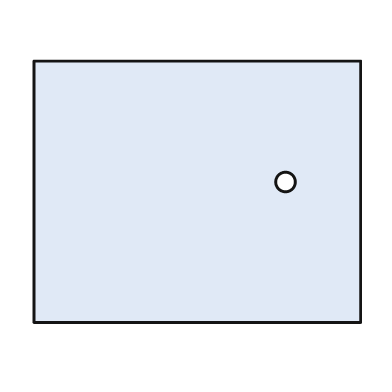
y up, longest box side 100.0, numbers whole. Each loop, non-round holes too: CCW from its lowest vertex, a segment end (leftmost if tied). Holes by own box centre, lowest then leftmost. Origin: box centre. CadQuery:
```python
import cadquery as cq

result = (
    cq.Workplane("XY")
    .moveTo(-50.0, -40.0)
    .lineTo(50.0, -40.0)
    .lineTo(50.0, 40.0)
    .lineTo(-50.0, 40.0)
    .close()
    .moveTo(27.0, 3.0)
    .circle(3.0)
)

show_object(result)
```